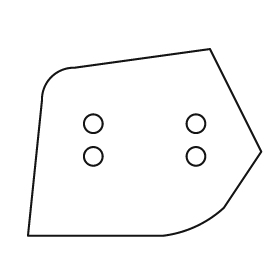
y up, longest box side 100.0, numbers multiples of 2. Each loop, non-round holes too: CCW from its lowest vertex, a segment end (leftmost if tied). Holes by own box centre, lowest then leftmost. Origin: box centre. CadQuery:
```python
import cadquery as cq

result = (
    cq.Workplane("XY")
    .moveTo(-50.0, -40.0)
    .lineTo(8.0, -40.0)
    .threePointArc((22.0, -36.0), (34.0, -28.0))
    .lineTo(50.0, -4.0)
    .lineTo(28.0, 40.0)
    .lineTo(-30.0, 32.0)
    .threePointArc((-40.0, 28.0), (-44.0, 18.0))
    .close()
    .moveTo(-22.0, -6.0)
    .circle(4.0)
    .moveTo(22.0, -6.0)
    .circle(4.0)
    .moveTo(-22.0, 8.0)
    .circle(4.0)
    .moveTo(22.0, 8.0)
    .circle(4.0)
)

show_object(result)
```